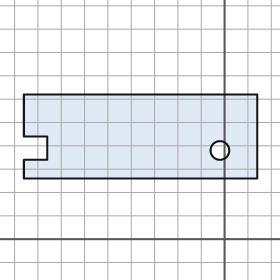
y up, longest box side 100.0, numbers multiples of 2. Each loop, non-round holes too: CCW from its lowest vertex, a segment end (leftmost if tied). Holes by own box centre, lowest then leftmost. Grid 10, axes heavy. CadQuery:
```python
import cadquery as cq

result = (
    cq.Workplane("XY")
    .moveTo(-86.0, 26.0)
    .lineTo(14.0, 26.0)
    .lineTo(14.0, 62.0)
    .lineTo(-86.0, 62.0)
    .lineTo(-86.0, 44.0)
    .lineTo(-76.0, 44.0)
    .lineTo(-76.0, 34.0)
    .lineTo(-86.0, 34.0)
    .close()
    .moveTo(-2.0, 38.0)
    .circle(4.0)
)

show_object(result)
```